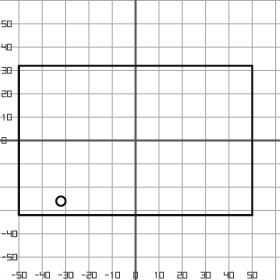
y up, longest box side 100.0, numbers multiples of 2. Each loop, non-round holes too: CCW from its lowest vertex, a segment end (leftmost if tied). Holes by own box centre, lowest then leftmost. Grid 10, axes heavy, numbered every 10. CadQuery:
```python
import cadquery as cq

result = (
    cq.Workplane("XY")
    .moveTo(-50.0, -32.0)
    .lineTo(50.0, -32.0)
    .lineTo(50.0, 32.0)
    .lineTo(-50.0, 32.0)
    .close()
    .moveTo(-32.0, -26.0)
    .circle(2.0)
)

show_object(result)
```